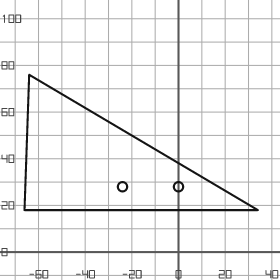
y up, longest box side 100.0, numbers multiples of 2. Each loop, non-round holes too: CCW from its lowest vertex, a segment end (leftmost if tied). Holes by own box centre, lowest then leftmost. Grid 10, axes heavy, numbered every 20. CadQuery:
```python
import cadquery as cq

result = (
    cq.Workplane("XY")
    .moveTo(-66.0, 18.0)
    .lineTo(34.0, 18.0)
    .lineTo(-64.0, 76.0)
    .close()
    .moveTo(-24.0, 28.0)
    .circle(2.0)
    .moveTo(0.0, 28.0)
    .circle(2.0)
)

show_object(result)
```